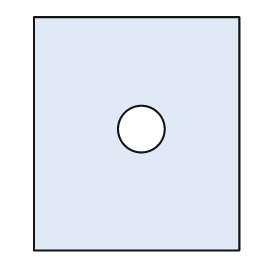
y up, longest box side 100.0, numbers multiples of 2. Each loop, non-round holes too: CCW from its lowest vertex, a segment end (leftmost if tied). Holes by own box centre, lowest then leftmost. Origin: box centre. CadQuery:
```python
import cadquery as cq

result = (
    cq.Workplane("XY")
    .moveTo(-44.0, -50.0)
    .lineTo(44.0, -50.0)
    .lineTo(44.0, 50.0)
    .lineTo(-44.0, 50.0)
    .close()
    .moveTo(2.0, 2.0)
    .circle(10.0)
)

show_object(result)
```